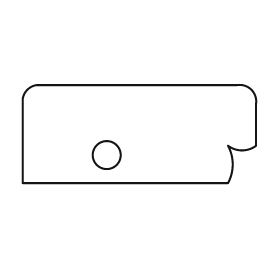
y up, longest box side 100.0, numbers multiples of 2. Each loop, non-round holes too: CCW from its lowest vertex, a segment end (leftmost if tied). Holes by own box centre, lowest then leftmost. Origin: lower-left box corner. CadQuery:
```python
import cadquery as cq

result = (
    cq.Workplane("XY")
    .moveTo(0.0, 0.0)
    .lineTo(88.0, 0.0)
    .threePointArc((90.0, 8.0), (88.0, 16.0))
    .threePointArc((94.0, 14.0), (100.0, 16.0))
    .lineTo(100.0, 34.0)
    .threePointArc((98.0, 40.0), (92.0, 42.0))
    .lineTo(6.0, 42.0)
    .threePointArc((2.0, 40.0), (0.0, 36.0))
    .close()
    .moveTo(36.0, 12.0)
    .circle(6.0)
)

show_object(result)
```